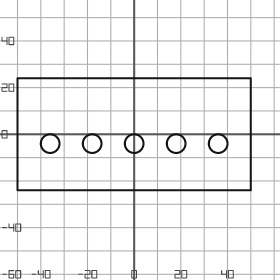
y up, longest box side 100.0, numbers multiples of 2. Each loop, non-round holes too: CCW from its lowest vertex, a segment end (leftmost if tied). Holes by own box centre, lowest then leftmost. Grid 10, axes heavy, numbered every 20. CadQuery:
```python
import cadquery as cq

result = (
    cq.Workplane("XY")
    .moveTo(-50.0, -24.0)
    .lineTo(50.0, -24.0)
    .lineTo(50.0, 24.0)
    .lineTo(-50.0, 24.0)
    .close()
    .moveTo(-36.0, -4.0)
    .circle(4.0)
    .moveTo(-18.0, -4.0)
    .circle(4.0)
    .moveTo(0.0, -4.0)
    .circle(4.0)
    .moveTo(18.0, -4.0)
    .circle(4.0)
    .moveTo(36.0, -4.0)
    .circle(4.0)
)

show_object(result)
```